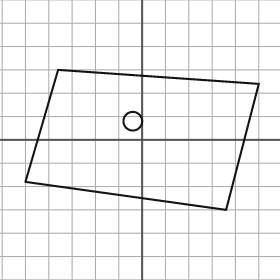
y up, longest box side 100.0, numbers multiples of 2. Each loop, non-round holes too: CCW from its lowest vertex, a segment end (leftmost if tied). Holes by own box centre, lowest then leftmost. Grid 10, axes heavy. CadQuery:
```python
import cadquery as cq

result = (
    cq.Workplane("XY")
    .moveTo(36.0, -30.0)
    .lineTo(50.0, 24.0)
    .lineTo(-36.0, 30.0)
    .lineTo(-50.0, -18.0)
    .close()
    .moveTo(-4.0, 8.0)
    .circle(4.0)
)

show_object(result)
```